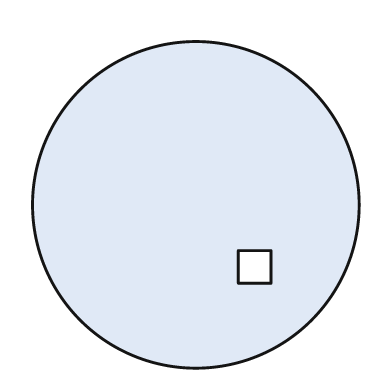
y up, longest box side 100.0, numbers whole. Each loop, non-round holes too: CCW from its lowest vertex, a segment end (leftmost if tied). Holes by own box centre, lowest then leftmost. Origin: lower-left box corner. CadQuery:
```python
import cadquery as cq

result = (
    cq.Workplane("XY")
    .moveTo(50.0, 50.0)
    .circle(50.0)
    .moveTo(63.0, 26.0)
    .lineTo(73.0, 26.0)
    .lineTo(73.0, 36.0)
    .lineTo(63.0, 36.0)
    .close()
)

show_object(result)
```